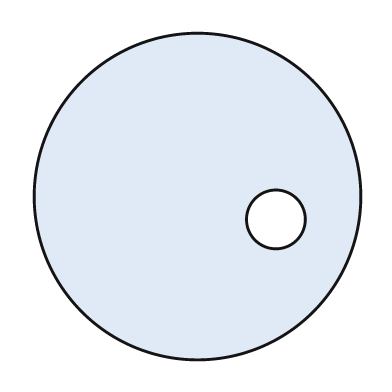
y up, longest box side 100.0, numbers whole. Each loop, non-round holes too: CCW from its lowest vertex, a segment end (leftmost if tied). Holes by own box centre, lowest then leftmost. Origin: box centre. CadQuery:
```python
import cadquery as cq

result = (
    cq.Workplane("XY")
    .moveTo(0.0, 0.0)
    .circle(50.0)
    .moveTo(24.0, -7.0)
    .circle(9.0)
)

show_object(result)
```